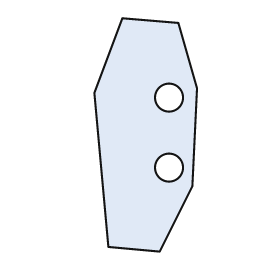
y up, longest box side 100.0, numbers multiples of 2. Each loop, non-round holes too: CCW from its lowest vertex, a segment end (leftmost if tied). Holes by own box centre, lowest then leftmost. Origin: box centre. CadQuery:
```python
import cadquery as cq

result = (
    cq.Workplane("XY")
    .moveTo(6.0, -50.0)
    .lineTo(20.0, -22.0)
    .lineTo(22.0, 20.0)
    .lineTo(14.0, 48.0)
    .lineTo(-10.0, 50.0)
    .lineTo(-22.0, 18.0)
    .lineTo(-16.0, -48.0)
    .close()
    .moveTo(10.0, -14.0)
    .circle(6.0)
    .moveTo(10.0, 16.0)
    .circle(6.0)
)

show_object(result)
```